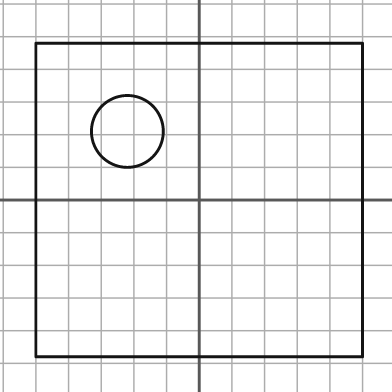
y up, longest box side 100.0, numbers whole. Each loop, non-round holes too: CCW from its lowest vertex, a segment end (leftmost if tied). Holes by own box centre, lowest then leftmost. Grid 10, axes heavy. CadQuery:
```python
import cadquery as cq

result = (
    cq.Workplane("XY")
    .moveTo(-50.0, -48.0)
    .lineTo(50.0, -48.0)
    .lineTo(50.0, 48.0)
    .lineTo(-50.0, 48.0)
    .close()
    .moveTo(-22.0, 21.0)
    .circle(11.0)
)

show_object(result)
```